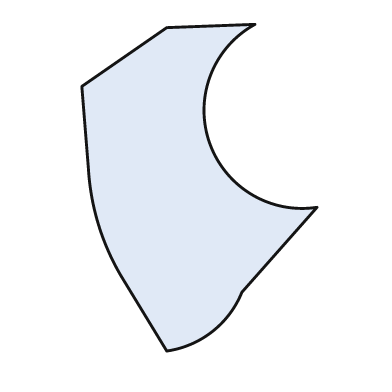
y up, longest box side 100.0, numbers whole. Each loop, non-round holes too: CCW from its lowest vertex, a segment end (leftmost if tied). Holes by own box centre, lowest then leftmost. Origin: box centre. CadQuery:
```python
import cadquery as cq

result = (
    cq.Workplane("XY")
    .moveTo(-10.0, -50.0)
    .threePointArc((4.0, -44.0), (13.0, -32.0))
    .lineTo(36.0, -6.0)
    .threePointArc((3.0, 14.0), (17.0, 50.0))
    .lineTo(-10.0, 49.0)
    .lineTo(-36.0, 31.0)
    .lineTo(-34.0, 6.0)
    .threePointArc((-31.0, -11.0), (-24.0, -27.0))
    .close()
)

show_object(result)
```